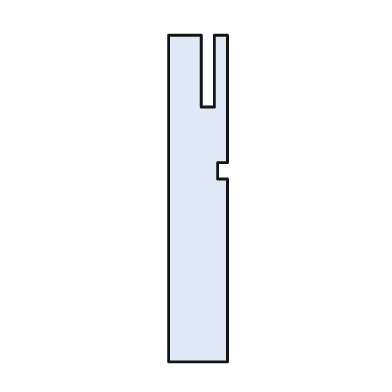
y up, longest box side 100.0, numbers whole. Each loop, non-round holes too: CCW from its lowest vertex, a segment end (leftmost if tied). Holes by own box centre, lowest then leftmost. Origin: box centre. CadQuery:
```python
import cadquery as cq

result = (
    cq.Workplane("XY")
    .moveTo(-9.0, -50.0)
    .lineTo(9.0, -50.0)
    .lineTo(9.0, 6.0)
    .lineTo(6.0, 6.0)
    .lineTo(6.0, 11.0)
    .lineTo(9.0, 11.0)
    .lineTo(9.0, 50.0)
    .lineTo(5.0, 50.0)
    .lineTo(5.0, 28.0)
    .lineTo(1.0, 28.0)
    .lineTo(1.0, 50.0)
    .lineTo(-9.0, 50.0)
    .close()
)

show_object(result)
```